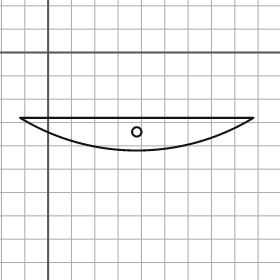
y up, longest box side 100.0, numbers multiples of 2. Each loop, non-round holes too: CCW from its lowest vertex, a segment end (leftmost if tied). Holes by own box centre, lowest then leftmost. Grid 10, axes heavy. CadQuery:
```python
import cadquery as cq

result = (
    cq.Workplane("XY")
    .moveTo(-12.0, -28.0)
    .threePointArc((38.0, -42.0), (88.0, -28.0))
    .close()
    .moveTo(38.0, -34.0)
    .circle(2.0)
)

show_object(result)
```